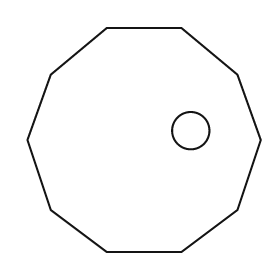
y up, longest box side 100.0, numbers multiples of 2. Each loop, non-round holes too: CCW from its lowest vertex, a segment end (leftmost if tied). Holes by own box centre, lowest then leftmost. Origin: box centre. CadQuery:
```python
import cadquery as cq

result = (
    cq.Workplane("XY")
    .moveTo(-16.0, -48.0)
    .lineTo(16.0, -48.0)
    .lineTo(40.0, -30.0)
    .lineTo(50.0, 0.0)
    .lineTo(40.0, 28.0)
    .lineTo(16.0, 48.0)
    .lineTo(-16.0, 48.0)
    .lineTo(-40.0, 28.0)
    .lineTo(-50.0, 0.0)
    .lineTo(-40.0, -30.0)
    .close()
    .moveTo(20.0, 4.0)
    .circle(8.0)
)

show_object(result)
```